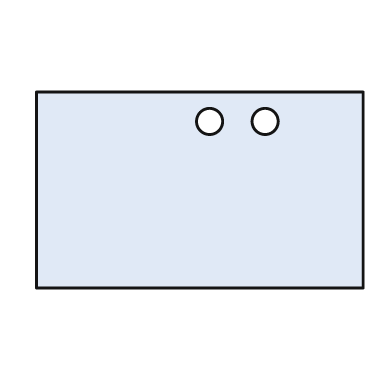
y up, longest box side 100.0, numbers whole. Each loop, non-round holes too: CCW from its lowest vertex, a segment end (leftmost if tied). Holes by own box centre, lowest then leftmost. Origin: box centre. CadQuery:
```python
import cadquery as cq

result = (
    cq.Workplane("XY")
    .moveTo(-50.0, -30.0)
    .lineTo(50.0, -30.0)
    .lineTo(50.0, 30.0)
    .lineTo(-50.0, 30.0)
    .close()
    .moveTo(3.0, 21.0)
    .circle(4.0)
    .moveTo(20.0, 21.0)
    .circle(4.0)
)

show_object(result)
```